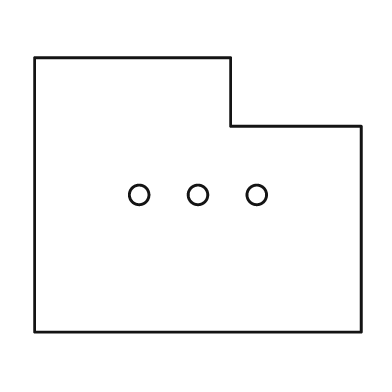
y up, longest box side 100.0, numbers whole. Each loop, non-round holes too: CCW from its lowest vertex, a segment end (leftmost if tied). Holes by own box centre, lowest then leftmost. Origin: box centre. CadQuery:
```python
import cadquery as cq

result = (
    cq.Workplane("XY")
    .moveTo(-50.0, -42.0)
    .lineTo(50.0, -42.0)
    .lineTo(50.0, 21.0)
    .lineTo(10.0, 21.0)
    .lineTo(10.0, 42.0)
    .lineTo(-50.0, 42.0)
    .close()
    .moveTo(-18.0, 0.0)
    .circle(3.0)
    .moveTo(0.0, 0.0)
    .circle(3.0)
    .moveTo(18.0, 0.0)
    .circle(3.0)
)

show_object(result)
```